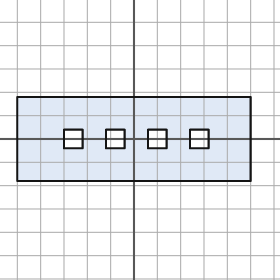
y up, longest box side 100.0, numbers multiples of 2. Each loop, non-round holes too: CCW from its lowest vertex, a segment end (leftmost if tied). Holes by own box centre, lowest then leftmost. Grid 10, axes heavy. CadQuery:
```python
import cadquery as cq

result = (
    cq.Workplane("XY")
    .moveTo(-50.0, -18.0)
    .lineTo(50.0, -18.0)
    .lineTo(50.0, 18.0)
    .lineTo(-50.0, 18.0)
    .close()
    .moveTo(-30.0, -4.0)
    .lineTo(-22.0, -4.0)
    .lineTo(-22.0, 4.0)
    .lineTo(-30.0, 4.0)
    .close()
    .moveTo(-12.0, -4.0)
    .lineTo(-4.0, -4.0)
    .lineTo(-4.0, 4.0)
    .lineTo(-12.0, 4.0)
    .close()
    .moveTo(6.0, -4.0)
    .lineTo(14.0, -4.0)
    .lineTo(14.0, 4.0)
    .lineTo(6.0, 4.0)
    .close()
    .moveTo(24.0, -4.0)
    .lineTo(32.0, -4.0)
    .lineTo(32.0, 4.0)
    .lineTo(24.0, 4.0)
    .close()
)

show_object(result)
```